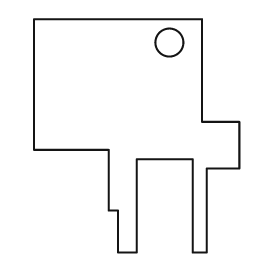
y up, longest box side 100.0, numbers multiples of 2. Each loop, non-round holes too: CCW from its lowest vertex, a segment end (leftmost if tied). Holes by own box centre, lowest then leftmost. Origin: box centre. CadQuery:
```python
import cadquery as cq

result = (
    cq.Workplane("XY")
    .moveTo(-8.0, -50.0)
    .lineTo(0.0, -50.0)
    .lineTo(0.0, -10.0)
    .lineTo(24.0, -10.0)
    .lineTo(24.0, -50.0)
    .lineTo(30.0, -50.0)
    .lineTo(30.0, -14.0)
    .lineTo(44.0, -14.0)
    .lineTo(44.0, 6.0)
    .lineTo(28.0, 6.0)
    .lineTo(28.0, 50.0)
    .lineTo(-44.0, 50.0)
    .lineTo(-44.0, -6.0)
    .lineTo(-12.0, -6.0)
    .lineTo(-12.0, -32.0)
    .lineTo(-8.0, -32.0)
    .close()
    .moveTo(14.0, 40.0)
    .circle(6.0)
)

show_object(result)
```